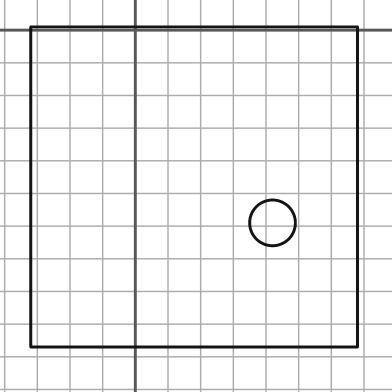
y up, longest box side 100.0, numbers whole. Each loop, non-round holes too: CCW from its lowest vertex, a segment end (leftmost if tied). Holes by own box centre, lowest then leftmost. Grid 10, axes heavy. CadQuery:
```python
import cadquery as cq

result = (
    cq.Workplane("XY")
    .moveTo(-32.0, -97.0)
    .lineTo(68.0, -97.0)
    .lineTo(68.0, 1.0)
    .lineTo(-32.0, 1.0)
    .close()
    .moveTo(42.0, -59.0)
    .circle(7.0)
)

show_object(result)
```